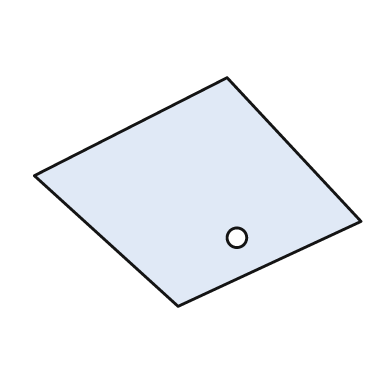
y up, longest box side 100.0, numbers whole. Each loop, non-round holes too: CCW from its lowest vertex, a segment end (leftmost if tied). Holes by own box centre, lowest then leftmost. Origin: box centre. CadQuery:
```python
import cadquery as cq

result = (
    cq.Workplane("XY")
    .moveTo(-6.0, -35.0)
    .lineTo(50.0, -9.0)
    .lineTo(9.0, 35.0)
    .lineTo(-50.0, 5.0)
    .close()
    .moveTo(12.0, -14.0)
    .circle(3.0)
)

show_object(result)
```